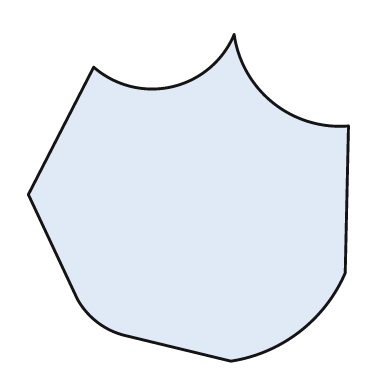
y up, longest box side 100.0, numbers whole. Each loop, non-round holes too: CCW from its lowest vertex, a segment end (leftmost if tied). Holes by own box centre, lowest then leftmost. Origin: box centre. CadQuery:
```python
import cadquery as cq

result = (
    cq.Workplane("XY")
    .moveTo(13.0, -50.0)
    .threePointArc((34.0, -41.0), (48.0, -23.0))
    .lineTo(49.0, 22.0)
    .threePointArc((26.0, 29.0), (14.0, 50.0))
    .threePointArc((-5.0, 34.0), (-29.0, 40.0))
    .lineTo(-49.0, 1.0)
    .lineTo(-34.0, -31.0)
    .threePointArc((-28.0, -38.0), (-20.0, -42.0))
    .close()
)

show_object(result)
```